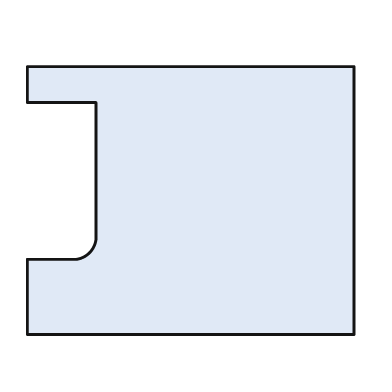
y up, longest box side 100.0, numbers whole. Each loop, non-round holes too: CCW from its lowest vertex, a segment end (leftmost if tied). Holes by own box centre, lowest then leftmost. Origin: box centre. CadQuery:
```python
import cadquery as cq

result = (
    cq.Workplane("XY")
    .moveTo(-50.0, -41.0)
    .lineTo(50.0, -41.0)
    .lineTo(50.0, 41.0)
    .lineTo(-50.0, 41.0)
    .lineTo(-50.0, 30.0)
    .lineTo(-29.0, 30.0)
    .lineTo(-29.0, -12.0)
    .threePointArc((-31.0, -16.0), (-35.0, -18.0))
    .lineTo(-50.0, -18.0)
    .close()
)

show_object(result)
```